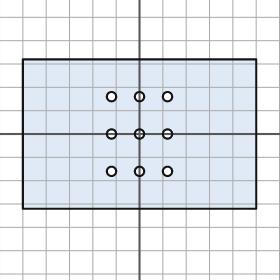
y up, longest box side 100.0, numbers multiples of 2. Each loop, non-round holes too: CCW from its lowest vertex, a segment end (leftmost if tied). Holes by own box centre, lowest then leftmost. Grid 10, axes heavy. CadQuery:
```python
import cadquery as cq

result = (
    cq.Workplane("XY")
    .moveTo(-50.0, -32.0)
    .lineTo(50.0, -32.0)
    .lineTo(50.0, 32.0)
    .lineTo(-50.0, 32.0)
    .close()
    .moveTo(-12.0, -16.0)
    .circle(2.0)
    .moveTo(0.0, -16.0)
    .circle(2.0)
    .moveTo(12.0, -16.0)
    .circle(2.0)
    .moveTo(-12.0, 0.0)
    .circle(2.0)
    .moveTo(0.0, 0.0)
    .circle(2.0)
    .moveTo(12.0, 0.0)
    .circle(2.0)
    .moveTo(-12.0, 16.0)
    .circle(2.0)
    .moveTo(0.0, 16.0)
    .circle(2.0)
    .moveTo(12.0, 16.0)
    .circle(2.0)
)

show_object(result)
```